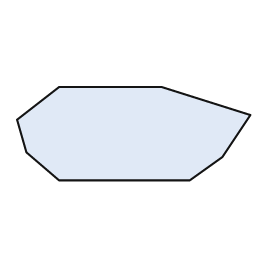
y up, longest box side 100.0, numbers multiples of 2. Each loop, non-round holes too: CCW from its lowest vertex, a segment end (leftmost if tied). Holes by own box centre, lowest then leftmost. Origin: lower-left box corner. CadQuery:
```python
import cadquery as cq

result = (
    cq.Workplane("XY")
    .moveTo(18.0, 0.0)
    .lineTo(74.0, 0.0)
    .lineTo(88.0, 10.0)
    .lineTo(100.0, 28.0)
    .lineTo(62.0, 40.0)
    .lineTo(18.0, 40.0)
    .lineTo(0.0, 26.0)
    .lineTo(4.0, 12.0)
    .close()
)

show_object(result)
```